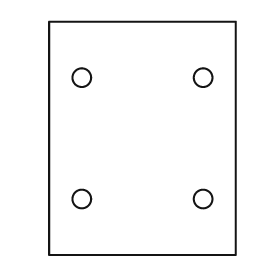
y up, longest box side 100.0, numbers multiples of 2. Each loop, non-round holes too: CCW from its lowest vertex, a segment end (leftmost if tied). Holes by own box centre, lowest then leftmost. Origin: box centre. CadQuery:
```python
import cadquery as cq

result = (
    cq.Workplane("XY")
    .moveTo(-40.0, -50.0)
    .lineTo(40.0, -50.0)
    .lineTo(40.0, 50.0)
    .lineTo(-40.0, 50.0)
    .close()
    .moveTo(-26.0, -26.0)
    .circle(4.0)
    .moveTo(26.0, -26.0)
    .circle(4.0)
    .moveTo(-26.0, 26.0)
    .circle(4.0)
    .moveTo(26.0, 26.0)
    .circle(4.0)
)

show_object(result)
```